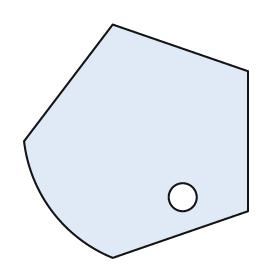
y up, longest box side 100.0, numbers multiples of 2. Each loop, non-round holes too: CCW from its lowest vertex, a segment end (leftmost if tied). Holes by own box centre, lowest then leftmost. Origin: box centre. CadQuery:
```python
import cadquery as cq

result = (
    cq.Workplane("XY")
    .moveTo(-10.0, -50.0)
    .lineTo(48.0, -30.0)
    .lineTo(48.0, 30.0)
    .lineTo(-10.0, 50.0)
    .lineTo(-48.0, 0.0)
    .threePointArc((-36.0, -30.0), (-10.0, -50.0))
    .close()
    .moveTo(20.0, -24.0)
    .circle(6.0)
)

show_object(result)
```